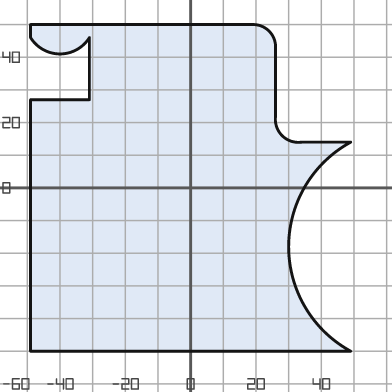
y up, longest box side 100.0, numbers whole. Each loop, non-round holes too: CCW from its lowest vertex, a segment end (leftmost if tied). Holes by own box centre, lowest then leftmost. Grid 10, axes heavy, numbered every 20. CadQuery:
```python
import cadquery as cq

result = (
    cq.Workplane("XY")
    .moveTo(-49.0, -50.0)
    .lineTo(49.0, -50.0)
    .threePointArc((30.0, -18.0), (49.0, 14.0))
    .lineTo(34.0, 14.0)
    .threePointArc((28.0, 16.0), (26.0, 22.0))
    .lineTo(26.0, 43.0)
    .threePointArc((24.0, 48.0), (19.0, 50.0))
    .lineTo(-49.0, 50.0)
    .lineTo(-49.0, 46.0)
    .threePointArc((-40.0, 41.0), (-31.0, 46.0))
    .lineTo(-31.0, 27.0)
    .lineTo(-49.0, 27.0)
    .close()
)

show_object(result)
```